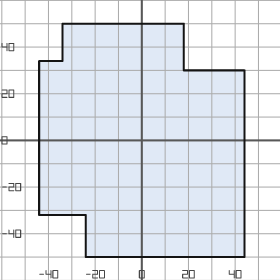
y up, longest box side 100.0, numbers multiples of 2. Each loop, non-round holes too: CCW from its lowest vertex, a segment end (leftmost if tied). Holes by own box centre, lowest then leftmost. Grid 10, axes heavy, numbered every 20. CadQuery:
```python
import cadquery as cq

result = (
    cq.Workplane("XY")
    .moveTo(-24.0, -50.0)
    .lineTo(44.0, -50.0)
    .lineTo(44.0, 30.0)
    .lineTo(18.0, 30.0)
    .lineTo(18.0, 50.0)
    .lineTo(-34.0, 50.0)
    .lineTo(-34.0, 34.0)
    .lineTo(-44.0, 34.0)
    .lineTo(-44.0, -32.0)
    .lineTo(-24.0, -32.0)
    .close()
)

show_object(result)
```